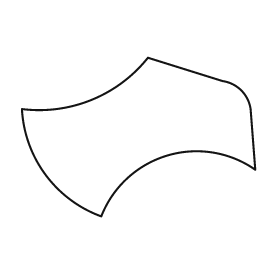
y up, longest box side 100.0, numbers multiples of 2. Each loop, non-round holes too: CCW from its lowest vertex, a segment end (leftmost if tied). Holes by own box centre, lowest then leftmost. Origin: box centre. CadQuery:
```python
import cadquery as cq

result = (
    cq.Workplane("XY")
    .moveTo(-16.0, -34.0)
    .threePointArc((12.0, -8.0), (50.0, -14.0))
    .lineTo(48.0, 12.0)
    .threePointArc((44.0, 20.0), (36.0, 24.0))
    .lineTo(4.0, 34.0)
    .threePointArc((-20.0, 16.0), (-50.0, 12.0))
    .threePointArc((-40.0, -16.0), (-16.0, -34.0))
    .close()
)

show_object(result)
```